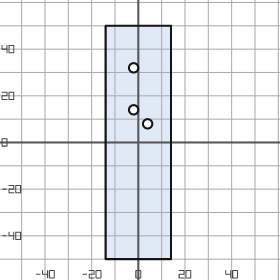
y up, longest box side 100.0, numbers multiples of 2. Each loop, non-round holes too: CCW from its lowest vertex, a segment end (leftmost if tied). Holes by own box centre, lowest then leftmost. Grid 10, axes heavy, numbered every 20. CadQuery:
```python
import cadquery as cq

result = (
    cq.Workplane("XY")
    .moveTo(-14.0, -50.0)
    .lineTo(14.0, -50.0)
    .lineTo(14.0, 50.0)
    .lineTo(-14.0, 50.0)
    .close()
    .moveTo(4.0, 8.0)
    .circle(2.0)
    .moveTo(-2.0, 14.0)
    .circle(2.0)
    .moveTo(-2.0, 32.0)
    .circle(2.0)
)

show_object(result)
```